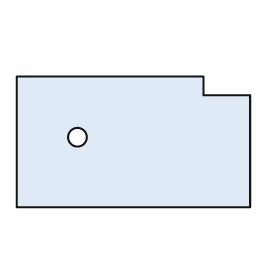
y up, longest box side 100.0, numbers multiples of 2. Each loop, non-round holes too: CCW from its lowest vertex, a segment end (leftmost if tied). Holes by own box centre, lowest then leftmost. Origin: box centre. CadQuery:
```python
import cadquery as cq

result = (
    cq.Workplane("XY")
    .moveTo(-50.0, -28.0)
    .lineTo(50.0, -28.0)
    .lineTo(50.0, 20.0)
    .lineTo(30.0, 20.0)
    .lineTo(30.0, 28.0)
    .lineTo(-50.0, 28.0)
    .close()
    .moveTo(-24.0, 2.0)
    .circle(4.0)
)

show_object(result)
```